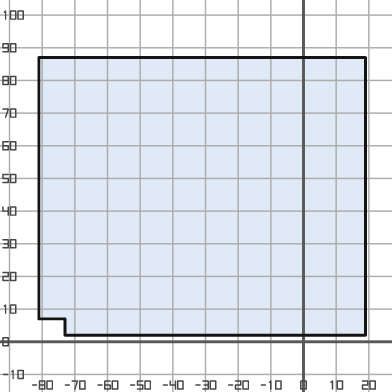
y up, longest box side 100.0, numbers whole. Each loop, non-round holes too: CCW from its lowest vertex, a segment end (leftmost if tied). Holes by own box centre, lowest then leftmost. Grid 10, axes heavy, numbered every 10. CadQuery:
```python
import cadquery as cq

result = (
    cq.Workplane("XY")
    .moveTo(-73.0, 2.0)
    .lineTo(19.0, 2.0)
    .lineTo(19.0, 87.0)
    .lineTo(-81.0, 87.0)
    .lineTo(-81.0, 7.0)
    .lineTo(-73.0, 7.0)
    .close()
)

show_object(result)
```